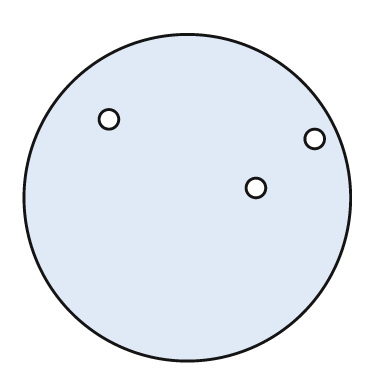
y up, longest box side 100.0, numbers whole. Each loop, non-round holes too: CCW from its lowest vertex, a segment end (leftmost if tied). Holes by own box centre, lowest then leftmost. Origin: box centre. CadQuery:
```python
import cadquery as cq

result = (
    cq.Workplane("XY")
    .moveTo(0.0, 0.0)
    .circle(50.0)
    .moveTo(21.0, 3.0)
    .circle(3.0)
    .moveTo(39.0, 18.0)
    .circle(3.0)
    .moveTo(-24.0, 24.0)
    .circle(3.0)
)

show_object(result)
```